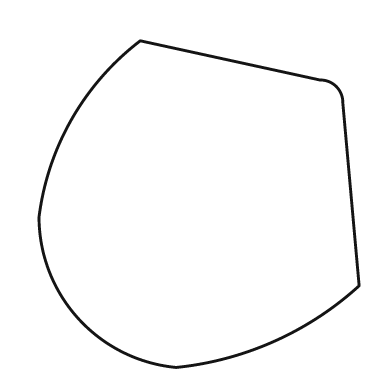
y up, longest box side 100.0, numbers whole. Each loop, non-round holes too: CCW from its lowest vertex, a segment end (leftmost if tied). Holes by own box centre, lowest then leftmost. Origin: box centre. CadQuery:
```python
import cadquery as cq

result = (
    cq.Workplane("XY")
    .moveTo(-7.0, -50.0)
    .threePointArc((23.0, -42.0), (49.0, -25.0))
    .lineTo(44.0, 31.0)
    .threePointArc((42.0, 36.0), (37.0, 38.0))
    .lineTo(-18.0, 50.0)
    .threePointArc((-39.0, 26.0), (-49.0, -4.0))
    .threePointArc((-37.0, -35.0), (-7.0, -50.0))
    .close()
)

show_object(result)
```